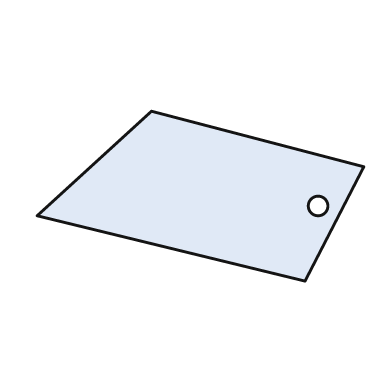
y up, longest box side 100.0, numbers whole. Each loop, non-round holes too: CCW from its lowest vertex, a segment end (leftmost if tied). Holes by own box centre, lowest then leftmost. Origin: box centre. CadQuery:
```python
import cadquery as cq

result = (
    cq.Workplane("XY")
    .moveTo(32.0, -26.0)
    .lineTo(50.0, 9.0)
    .lineTo(-15.0, 26.0)
    .lineTo(-50.0, -6.0)
    .close()
    .moveTo(36.0, -3.0)
    .circle(3.0)
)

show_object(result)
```